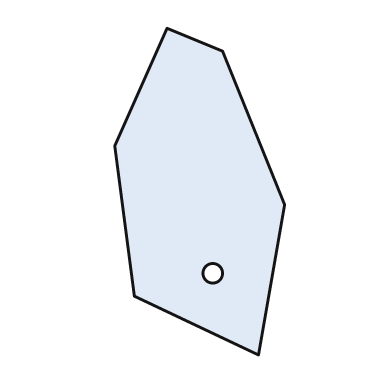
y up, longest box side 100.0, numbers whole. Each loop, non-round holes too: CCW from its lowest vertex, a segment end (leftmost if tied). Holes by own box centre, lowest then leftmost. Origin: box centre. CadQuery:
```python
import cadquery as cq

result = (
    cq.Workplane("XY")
    .moveTo(18.0, -50.0)
    .lineTo(26.0, -4.0)
    .lineTo(7.0, 43.0)
    .lineTo(-10.0, 50.0)
    .lineTo(-26.0, 14.0)
    .lineTo(-20.0, -32.0)
    .close()
    .moveTo(4.0, -25.0)
    .circle(3.0)
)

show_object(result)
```